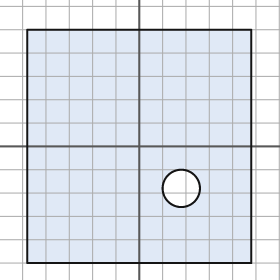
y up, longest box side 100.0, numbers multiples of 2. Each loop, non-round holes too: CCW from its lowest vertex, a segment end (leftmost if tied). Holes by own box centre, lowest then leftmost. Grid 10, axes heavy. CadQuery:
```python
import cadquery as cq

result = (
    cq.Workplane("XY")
    .moveTo(-48.0, -50.0)
    .lineTo(48.0, -50.0)
    .lineTo(48.0, 50.0)
    .lineTo(-48.0, 50.0)
    .close()
    .moveTo(18.0, -18.0)
    .circle(8.0)
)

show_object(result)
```